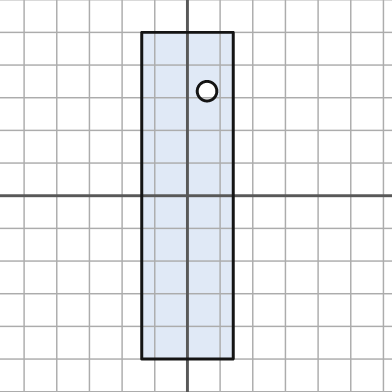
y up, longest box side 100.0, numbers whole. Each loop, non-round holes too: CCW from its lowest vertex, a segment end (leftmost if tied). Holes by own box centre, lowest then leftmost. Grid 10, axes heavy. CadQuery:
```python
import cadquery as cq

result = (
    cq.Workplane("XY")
    .moveTo(-14.0, -50.0)
    .lineTo(14.0, -50.0)
    .lineTo(14.0, 50.0)
    .lineTo(-14.0, 50.0)
    .close()
    .moveTo(6.0, 32.0)
    .circle(3.0)
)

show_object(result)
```